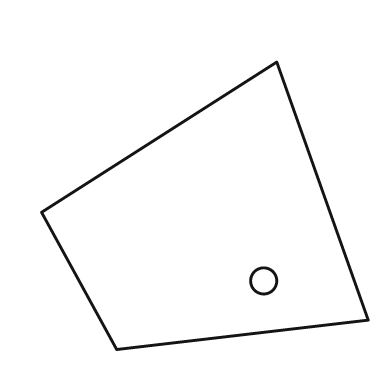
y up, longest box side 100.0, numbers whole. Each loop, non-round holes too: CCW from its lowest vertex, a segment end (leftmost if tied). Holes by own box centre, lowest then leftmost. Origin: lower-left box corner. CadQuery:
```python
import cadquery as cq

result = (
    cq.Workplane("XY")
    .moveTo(23.0, 0.0)
    .lineTo(100.0, 9.0)
    .lineTo(72.0, 88.0)
    .lineTo(0.0, 42.0)
    .close()
    .moveTo(68.0, 21.0)
    .circle(4.0)
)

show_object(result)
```